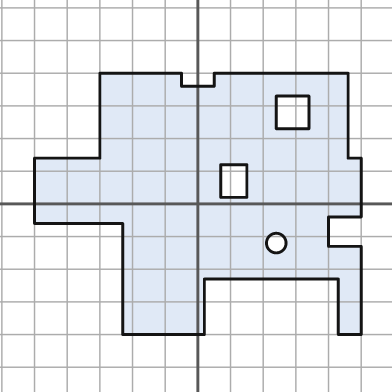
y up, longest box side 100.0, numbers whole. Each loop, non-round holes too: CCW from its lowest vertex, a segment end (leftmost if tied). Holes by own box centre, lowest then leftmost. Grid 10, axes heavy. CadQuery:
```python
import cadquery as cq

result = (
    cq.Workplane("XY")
    .moveTo(-23.0, -40.0)
    .lineTo(2.0, -40.0)
    .lineTo(2.0, -23.0)
    .lineTo(43.0, -23.0)
    .lineTo(43.0, -40.0)
    .lineTo(50.0, -40.0)
    .lineTo(50.0, -13.0)
    .lineTo(40.0, -13.0)
    .lineTo(40.0, -4.0)
    .lineTo(50.0, -4.0)
    .lineTo(50.0, 14.0)
    .lineTo(46.0, 14.0)
    .lineTo(46.0, 40.0)
    .lineTo(5.0, 40.0)
    .lineTo(5.0, 36.0)
    .lineTo(-5.0, 36.0)
    .lineTo(-5.0, 40.0)
    .lineTo(-30.0, 40.0)
    .lineTo(-30.0, 14.0)
    .lineTo(-50.0, 14.0)
    .lineTo(-50.0, -6.0)
    .lineTo(-23.0, -6.0)
    .close()
    .moveTo(24.0, -12.0)
    .circle(3.0)
    .moveTo(7.0, 2.0)
    .lineTo(15.0, 2.0)
    .lineTo(15.0, 12.0)
    .lineTo(7.0, 12.0)
    .close()
    .moveTo(24.0, 23.0)
    .lineTo(34.0, 23.0)
    .lineTo(34.0, 33.0)
    .lineTo(24.0, 33.0)
    .close()
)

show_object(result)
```